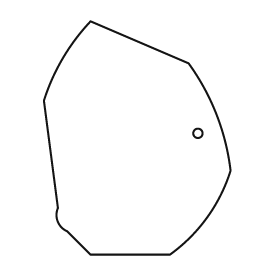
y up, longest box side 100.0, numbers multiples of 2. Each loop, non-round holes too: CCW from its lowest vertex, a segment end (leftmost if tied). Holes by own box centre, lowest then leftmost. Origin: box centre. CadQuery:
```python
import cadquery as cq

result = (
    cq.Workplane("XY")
    .moveTo(-20.0, -50.0)
    .lineTo(14.0, -50.0)
    .threePointArc((30.0, -34.0), (40.0, -14.0))
    .threePointArc((34.0, 10.0), (22.0, 32.0))
    .lineTo(-20.0, 50.0)
    .threePointArc((-32.0, 34.0), (-40.0, 16.0))
    .lineTo(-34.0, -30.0)
    .threePointArc((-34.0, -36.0), (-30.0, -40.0))
    .close()
    .moveTo(26.0, 2.0)
    .circle(2.0)
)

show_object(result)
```